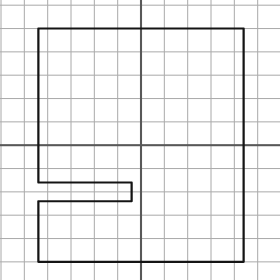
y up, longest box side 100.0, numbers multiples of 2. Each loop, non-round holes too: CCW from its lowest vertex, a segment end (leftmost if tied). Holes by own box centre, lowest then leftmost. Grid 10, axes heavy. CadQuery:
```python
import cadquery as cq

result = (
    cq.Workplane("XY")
    .moveTo(-44.0, -50.0)
    .lineTo(44.0, -50.0)
    .lineTo(44.0, 50.0)
    .lineTo(-44.0, 50.0)
    .lineTo(-44.0, -16.0)
    .lineTo(-4.0, -16.0)
    .lineTo(-4.0, -24.0)
    .lineTo(-44.0, -24.0)
    .close()
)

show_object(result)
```